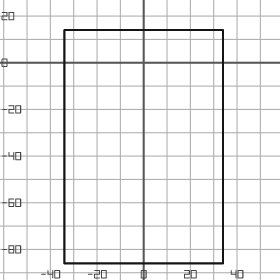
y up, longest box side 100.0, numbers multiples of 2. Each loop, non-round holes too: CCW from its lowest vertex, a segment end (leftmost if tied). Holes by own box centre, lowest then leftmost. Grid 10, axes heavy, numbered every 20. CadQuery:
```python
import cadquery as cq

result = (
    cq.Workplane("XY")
    .moveTo(-34.0, -86.0)
    .lineTo(34.0, -86.0)
    .lineTo(34.0, 14.0)
    .lineTo(-34.0, 14.0)
    .close()
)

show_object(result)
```